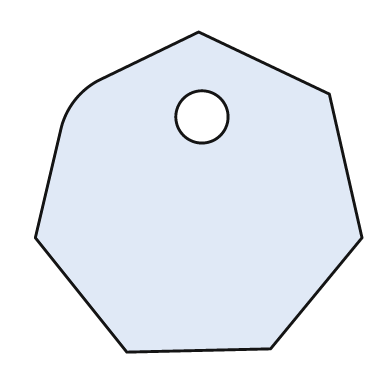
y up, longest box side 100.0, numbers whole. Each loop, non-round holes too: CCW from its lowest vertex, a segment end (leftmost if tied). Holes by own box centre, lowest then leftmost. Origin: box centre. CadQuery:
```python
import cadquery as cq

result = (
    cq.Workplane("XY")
    .moveTo(-22.0, -49.0)
    .lineTo(22.0, -48.0)
    .lineTo(50.0, -14.0)
    .lineTo(40.0, 30.0)
    .lineTo(0.0, 49.0)
    .lineTo(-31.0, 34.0)
    .threePointArc((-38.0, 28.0), (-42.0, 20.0))
    .lineTo(-50.0, -14.0)
    .close()
    .moveTo(1.0, 23.0)
    .circle(8.0)
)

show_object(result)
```